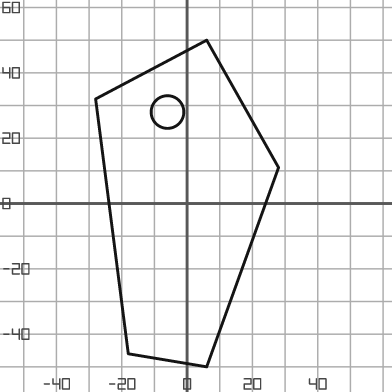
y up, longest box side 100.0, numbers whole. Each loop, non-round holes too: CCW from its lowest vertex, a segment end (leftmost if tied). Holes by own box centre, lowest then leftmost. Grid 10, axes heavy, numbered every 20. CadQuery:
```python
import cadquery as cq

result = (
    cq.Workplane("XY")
    .moveTo(6.0, -50.0)
    .lineTo(28.0, 11.0)
    .lineTo(6.0, 50.0)
    .lineTo(-28.0, 32.0)
    .lineTo(-18.0, -46.0)
    .close()
    .moveTo(-6.0, 28.0)
    .circle(5.0)
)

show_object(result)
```